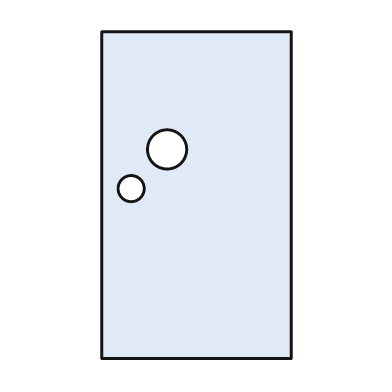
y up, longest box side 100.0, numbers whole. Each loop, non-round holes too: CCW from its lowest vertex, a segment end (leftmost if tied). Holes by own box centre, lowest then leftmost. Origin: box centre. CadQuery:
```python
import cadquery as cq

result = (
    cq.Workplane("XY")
    .moveTo(-29.0, -50.0)
    .lineTo(29.0, -50.0)
    .lineTo(29.0, 50.0)
    .lineTo(-29.0, 50.0)
    .close()
    .moveTo(-20.0, 2.0)
    .circle(4.0)
    .moveTo(-9.0, 14.0)
    .circle(6.0)
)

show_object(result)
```